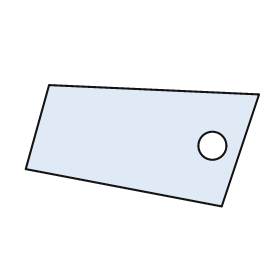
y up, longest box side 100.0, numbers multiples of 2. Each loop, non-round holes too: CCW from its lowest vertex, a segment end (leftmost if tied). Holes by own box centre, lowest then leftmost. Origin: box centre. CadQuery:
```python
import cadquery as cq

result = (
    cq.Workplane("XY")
    .moveTo(34.0, -26.0)
    .lineTo(50.0, 22.0)
    .lineTo(-40.0, 26.0)
    .lineTo(-50.0, -10.0)
    .close()
    .moveTo(30.0, 0.0)
    .circle(6.0)
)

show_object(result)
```